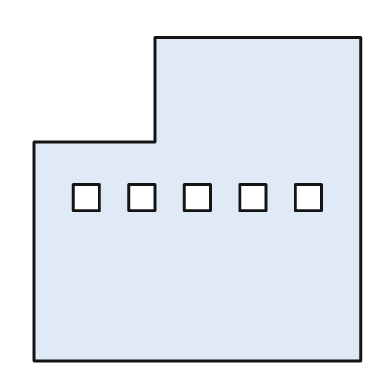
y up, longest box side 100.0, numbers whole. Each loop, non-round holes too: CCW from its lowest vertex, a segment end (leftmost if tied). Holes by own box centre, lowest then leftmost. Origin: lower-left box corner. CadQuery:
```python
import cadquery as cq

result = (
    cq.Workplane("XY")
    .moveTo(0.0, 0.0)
    .lineTo(100.0, 0.0)
    .lineTo(100.0, 99.0)
    .lineTo(37.0, 99.0)
    .lineTo(37.0, 67.0)
    .lineTo(0.0, 67.0)
    .close()
    .moveTo(12.0, 46.0)
    .lineTo(20.0, 46.0)
    .lineTo(20.0, 54.0)
    .lineTo(12.0, 54.0)
    .close()
    .moveTo(29.0, 46.0)
    .lineTo(37.0, 46.0)
    .lineTo(37.0, 54.0)
    .lineTo(29.0, 54.0)
    .close()
    .moveTo(46.0, 46.0)
    .lineTo(54.0, 46.0)
    .lineTo(54.0, 54.0)
    .lineTo(46.0, 54.0)
    .close()
    .moveTo(63.0, 46.0)
    .lineTo(71.0, 46.0)
    .lineTo(71.0, 54.0)
    .lineTo(63.0, 54.0)
    .close()
    .moveTo(80.0, 46.0)
    .lineTo(88.0, 46.0)
    .lineTo(88.0, 54.0)
    .lineTo(80.0, 54.0)
    .close()
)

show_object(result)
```